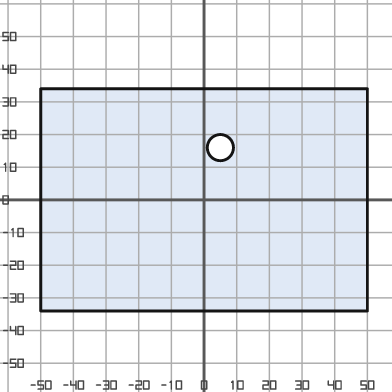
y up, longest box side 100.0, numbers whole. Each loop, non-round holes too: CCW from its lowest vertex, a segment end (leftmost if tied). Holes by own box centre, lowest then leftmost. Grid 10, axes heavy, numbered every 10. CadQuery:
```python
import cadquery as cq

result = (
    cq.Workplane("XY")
    .moveTo(-50.0, -34.0)
    .lineTo(50.0, -34.0)
    .lineTo(50.0, 34.0)
    .lineTo(-50.0, 34.0)
    .close()
    .moveTo(5.0, 16.0)
    .circle(4.0)
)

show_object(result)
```